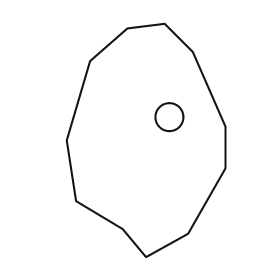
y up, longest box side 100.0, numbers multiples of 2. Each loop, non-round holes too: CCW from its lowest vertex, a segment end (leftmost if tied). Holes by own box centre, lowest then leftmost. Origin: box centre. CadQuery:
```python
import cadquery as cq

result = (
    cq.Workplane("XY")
    .moveTo(0.0, -50.0)
    .lineTo(18.0, -40.0)
    .lineTo(34.0, -12.0)
    .lineTo(34.0, 6.0)
    .lineTo(20.0, 38.0)
    .lineTo(8.0, 50.0)
    .lineTo(-8.0, 48.0)
    .lineTo(-24.0, 34.0)
    .lineTo(-34.0, 0.0)
    .lineTo(-30.0, -26.0)
    .lineTo(-10.0, -38.0)
    .close()
    .moveTo(10.0, 10.0)
    .circle(6.0)
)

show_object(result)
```